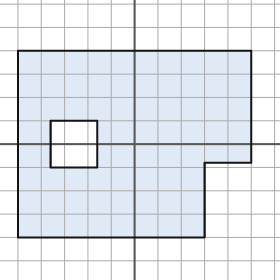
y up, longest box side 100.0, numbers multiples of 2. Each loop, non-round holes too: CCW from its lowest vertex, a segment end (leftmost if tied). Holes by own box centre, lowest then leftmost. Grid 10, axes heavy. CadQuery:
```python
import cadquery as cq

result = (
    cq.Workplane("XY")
    .moveTo(-50.0, -40.0)
    .lineTo(30.0, -40.0)
    .lineTo(30.0, -8.0)
    .lineTo(50.0, -8.0)
    .lineTo(50.0, 40.0)
    .lineTo(-50.0, 40.0)
    .close()
    .moveTo(-36.0, -10.0)
    .lineTo(-16.0, -10.0)
    .lineTo(-16.0, 10.0)
    .lineTo(-36.0, 10.0)
    .close()
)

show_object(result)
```